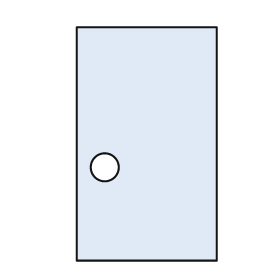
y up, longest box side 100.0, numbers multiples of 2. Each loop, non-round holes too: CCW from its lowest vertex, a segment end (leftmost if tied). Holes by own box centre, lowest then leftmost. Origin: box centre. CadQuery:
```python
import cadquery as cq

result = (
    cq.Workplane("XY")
    .moveTo(-30.0, -50.0)
    .lineTo(30.0, -50.0)
    .lineTo(30.0, 50.0)
    .lineTo(-30.0, 50.0)
    .close()
    .moveTo(-18.0, -10.0)
    .circle(6.0)
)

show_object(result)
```